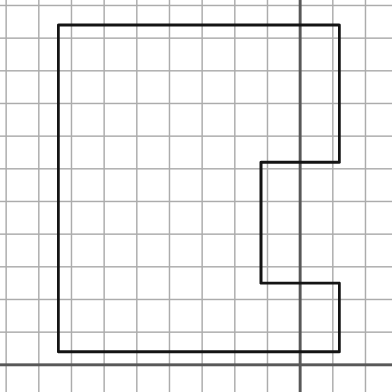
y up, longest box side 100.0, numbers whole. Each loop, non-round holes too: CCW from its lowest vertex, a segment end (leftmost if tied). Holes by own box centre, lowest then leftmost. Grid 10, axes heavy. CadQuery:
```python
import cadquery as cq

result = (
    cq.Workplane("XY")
    .moveTo(-74.0, 4.0)
    .lineTo(12.0, 4.0)
    .lineTo(12.0, 25.0)
    .lineTo(-12.0, 25.0)
    .lineTo(-12.0, 62.0)
    .lineTo(12.0, 62.0)
    .lineTo(12.0, 104.0)
    .lineTo(-74.0, 104.0)
    .close()
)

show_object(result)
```